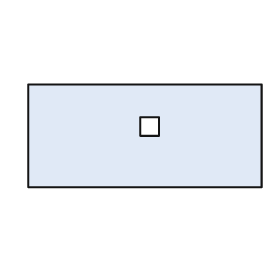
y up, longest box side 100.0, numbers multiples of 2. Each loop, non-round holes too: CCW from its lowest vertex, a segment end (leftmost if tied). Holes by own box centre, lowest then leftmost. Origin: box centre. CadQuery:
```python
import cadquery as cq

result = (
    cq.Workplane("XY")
    .moveTo(-50.0, -22.0)
    .lineTo(50.0, -22.0)
    .lineTo(50.0, 22.0)
    .lineTo(-50.0, 22.0)
    .close()
    .moveTo(-2.0, 0.0)
    .lineTo(6.0, 0.0)
    .lineTo(6.0, 8.0)
    .lineTo(-2.0, 8.0)
    .close()
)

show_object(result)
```